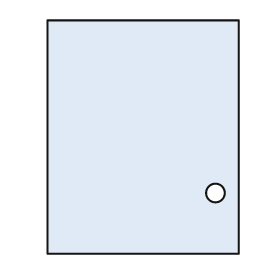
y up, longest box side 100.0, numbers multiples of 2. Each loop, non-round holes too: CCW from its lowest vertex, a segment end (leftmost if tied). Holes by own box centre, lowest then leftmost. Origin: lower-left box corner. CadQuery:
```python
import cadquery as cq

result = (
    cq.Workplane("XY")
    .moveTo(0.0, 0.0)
    .lineTo(82.0, 0.0)
    .lineTo(82.0, 100.0)
    .lineTo(0.0, 100.0)
    .close()
    .moveTo(72.0, 26.0)
    .circle(4.0)
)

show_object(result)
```